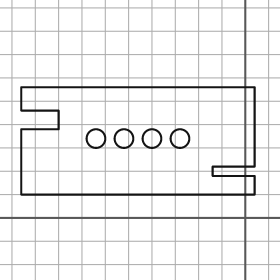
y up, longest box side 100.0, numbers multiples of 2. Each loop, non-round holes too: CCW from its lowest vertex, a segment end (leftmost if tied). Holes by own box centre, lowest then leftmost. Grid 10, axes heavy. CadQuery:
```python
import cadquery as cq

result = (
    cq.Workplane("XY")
    .moveTo(-96.0, 10.0)
    .lineTo(4.0, 10.0)
    .lineTo(4.0, 18.0)
    .lineTo(-14.0, 18.0)
    .lineTo(-14.0, 22.0)
    .lineTo(4.0, 22.0)
    .lineTo(4.0, 56.0)
    .lineTo(-96.0, 56.0)
    .lineTo(-96.0, 46.0)
    .lineTo(-80.0, 46.0)
    .lineTo(-80.0, 38.0)
    .lineTo(-96.0, 38.0)
    .close()
    .moveTo(-64.0, 34.0)
    .circle(4.0)
    .moveTo(-52.0, 34.0)
    .circle(4.0)
    .moveTo(-40.0, 34.0)
    .circle(4.0)
    .moveTo(-28.0, 34.0)
    .circle(4.0)
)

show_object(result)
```